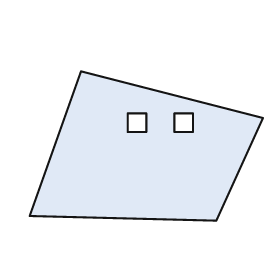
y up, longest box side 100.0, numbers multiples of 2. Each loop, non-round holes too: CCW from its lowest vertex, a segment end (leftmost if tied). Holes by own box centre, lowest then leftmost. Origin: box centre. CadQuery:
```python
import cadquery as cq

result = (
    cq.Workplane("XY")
    .moveTo(30.0, -32.0)
    .lineTo(50.0, 12.0)
    .lineTo(-28.0, 32.0)
    .lineTo(-50.0, -30.0)
    .close()
    .moveTo(-8.0, 6.0)
    .lineTo(0.0, 6.0)
    .lineTo(0.0, 14.0)
    .lineTo(-8.0, 14.0)
    .close()
    .moveTo(12.0, 6.0)
    .lineTo(20.0, 6.0)
    .lineTo(20.0, 14.0)
    .lineTo(12.0, 14.0)
    .close()
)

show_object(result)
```